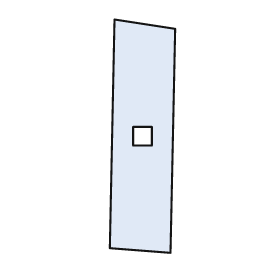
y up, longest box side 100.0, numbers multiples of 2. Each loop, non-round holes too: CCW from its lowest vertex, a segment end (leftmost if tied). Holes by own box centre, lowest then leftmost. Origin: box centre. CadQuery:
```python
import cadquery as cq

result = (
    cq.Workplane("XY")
    .moveTo(12.0, -50.0)
    .lineTo(14.0, 46.0)
    .lineTo(-12.0, 50.0)
    .lineTo(-14.0, -48.0)
    .close()
    .moveTo(-4.0, -4.0)
    .lineTo(4.0, -4.0)
    .lineTo(4.0, 4.0)
    .lineTo(-4.0, 4.0)
    .close()
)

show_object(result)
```